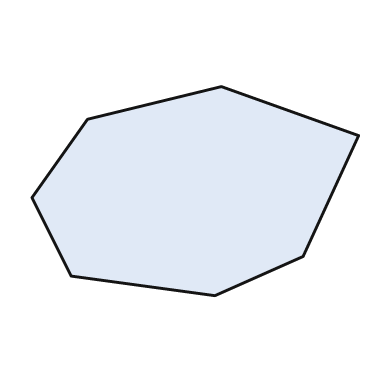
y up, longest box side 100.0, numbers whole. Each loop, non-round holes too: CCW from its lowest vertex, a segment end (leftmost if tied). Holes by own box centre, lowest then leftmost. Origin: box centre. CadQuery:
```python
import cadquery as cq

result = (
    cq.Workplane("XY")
    .moveTo(6.0, -32.0)
    .lineTo(33.0, -20.0)
    .lineTo(50.0, 17.0)
    .lineTo(8.0, 32.0)
    .lineTo(-33.0, 22.0)
    .lineTo(-50.0, -2.0)
    .lineTo(-38.0, -26.0)
    .close()
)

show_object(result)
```